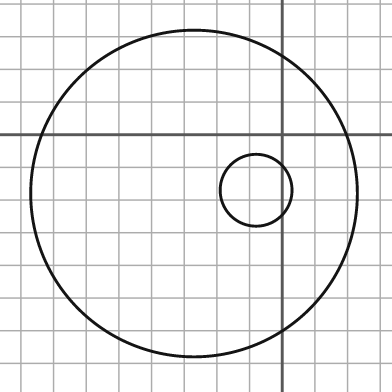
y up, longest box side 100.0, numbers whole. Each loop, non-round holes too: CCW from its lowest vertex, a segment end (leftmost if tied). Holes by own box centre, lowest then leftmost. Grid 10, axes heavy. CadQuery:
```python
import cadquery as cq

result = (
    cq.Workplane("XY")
    .moveTo(-27.0, -18.0)
    .circle(50.0)
    .moveTo(-8.0, -17.0)
    .circle(11.0)
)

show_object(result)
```